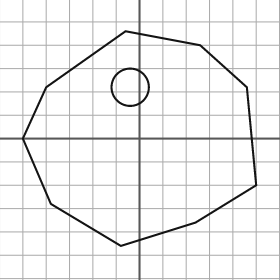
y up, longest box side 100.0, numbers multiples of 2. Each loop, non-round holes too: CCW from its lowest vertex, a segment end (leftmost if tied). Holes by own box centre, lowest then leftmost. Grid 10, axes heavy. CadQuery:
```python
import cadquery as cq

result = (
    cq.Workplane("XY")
    .moveTo(-8.0, -46.0)
    .lineTo(24.0, -36.0)
    .lineTo(50.0, -20.0)
    .lineTo(46.0, 22.0)
    .lineTo(26.0, 40.0)
    .lineTo(-6.0, 46.0)
    .lineTo(-40.0, 22.0)
    .lineTo(-50.0, 0.0)
    .lineTo(-38.0, -28.0)
    .close()
    .moveTo(-4.0, 22.0)
    .circle(8.0)
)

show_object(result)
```